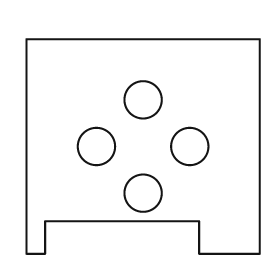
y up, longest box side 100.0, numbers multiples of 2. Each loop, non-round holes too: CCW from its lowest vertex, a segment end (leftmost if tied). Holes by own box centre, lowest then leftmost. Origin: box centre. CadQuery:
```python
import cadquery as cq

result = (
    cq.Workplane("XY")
    .moveTo(-50.0, -46.0)
    .lineTo(-42.0, -46.0)
    .lineTo(-42.0, -32.0)
    .lineTo(24.0, -32.0)
    .lineTo(24.0, -46.0)
    .lineTo(50.0, -46.0)
    .lineTo(50.0, 46.0)
    .lineTo(-50.0, 46.0)
    .close()
    .moveTo(0.0, -20.0)
    .circle(8.0)
    .moveTo(-20.0, 0.0)
    .circle(8.0)
    .moveTo(20.0, 0.0)
    .circle(8.0)
    .moveTo(0.0, 20.0)
    .circle(8.0)
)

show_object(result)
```